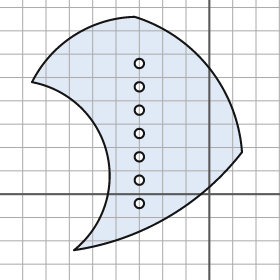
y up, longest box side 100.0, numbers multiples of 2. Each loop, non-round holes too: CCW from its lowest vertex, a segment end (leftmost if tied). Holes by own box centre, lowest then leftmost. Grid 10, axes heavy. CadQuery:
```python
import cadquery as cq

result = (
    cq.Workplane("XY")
    .moveTo(-58.0, -24.0)
    .threePointArc((-18.0, -10.0), (14.0, 18.0))
    .threePointArc((0.0, 54.0), (-32.0, 76.0))
    .threePointArc((-58.0, 68.0), (-76.0, 48.0))
    .threePointArc((-44.0, 18.0), (-58.0, -24.0))
    .close()
    .moveTo(-30.0, -4.0)
    .circle(2.0)
    .moveTo(-30.0, 6.0)
    .circle(2.0)
    .moveTo(-30.0, 16.0)
    .circle(2.0)
    .moveTo(-30.0, 26.0)
    .circle(2.0)
    .moveTo(-30.0, 36.0)
    .circle(2.0)
    .moveTo(-30.0, 46.0)
    .circle(2.0)
    .moveTo(-30.0, 56.0)
    .circle(2.0)
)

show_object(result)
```